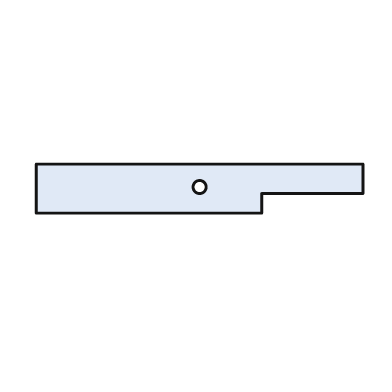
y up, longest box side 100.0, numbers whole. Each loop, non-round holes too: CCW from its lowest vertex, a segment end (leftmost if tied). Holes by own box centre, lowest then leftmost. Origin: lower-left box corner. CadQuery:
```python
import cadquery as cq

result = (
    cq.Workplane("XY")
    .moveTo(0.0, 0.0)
    .lineTo(69.0, 0.0)
    .lineTo(69.0, 6.0)
    .lineTo(100.0, 6.0)
    .lineTo(100.0, 15.0)
    .lineTo(0.0, 15.0)
    .close()
    .moveTo(50.0, 8.0)
    .circle(2.0)
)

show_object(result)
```